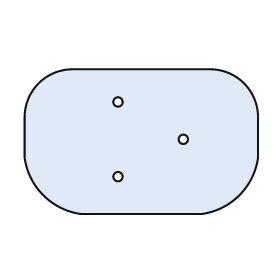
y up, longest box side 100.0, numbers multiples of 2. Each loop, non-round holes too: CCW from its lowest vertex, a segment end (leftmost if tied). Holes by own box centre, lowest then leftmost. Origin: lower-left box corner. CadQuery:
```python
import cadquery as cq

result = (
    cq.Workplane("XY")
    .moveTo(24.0, 0.0)
    .lineTo(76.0, 0.0)
    .threePointArc((92.0, 8.0), (100.0, 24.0))
    .lineTo(100.0, 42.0)
    .threePointArc((94.0, 56.0), (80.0, 62.0))
    .lineTo(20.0, 62.0)
    .threePointArc((6.0, 56.0), (0.0, 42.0))
    .lineTo(0.0, 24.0)
    .threePointArc((8.0, 8.0), (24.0, 0.0))
    .close()
    .moveTo(40.0, 16.0)
    .circle(2.0)
    .moveTo(68.0, 32.0)
    .circle(2.0)
    .moveTo(40.0, 48.0)
    .circle(2.0)
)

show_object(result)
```